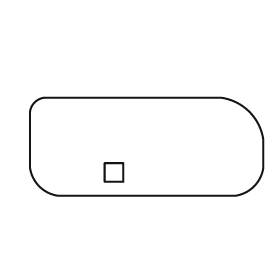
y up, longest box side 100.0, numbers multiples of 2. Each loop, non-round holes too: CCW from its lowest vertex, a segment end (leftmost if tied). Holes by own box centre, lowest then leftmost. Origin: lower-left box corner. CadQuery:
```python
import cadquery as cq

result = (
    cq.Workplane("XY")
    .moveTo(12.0, 0.0)
    .lineTo(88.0, 0.0)
    .threePointArc((96.0, 4.0), (100.0, 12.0))
    .lineTo(100.0, 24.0)
    .threePointArc((94.0, 36.0), (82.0, 42.0))
    .lineTo(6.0, 42.0)
    .threePointArc((2.0, 40.0), (0.0, 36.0))
    .lineTo(0.0, 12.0)
    .threePointArc((4.0, 4.0), (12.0, 0.0))
    .close()
    .moveTo(32.0, 6.0)
    .lineTo(40.0, 6.0)
    .lineTo(40.0, 14.0)
    .lineTo(32.0, 14.0)
    .close()
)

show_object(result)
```